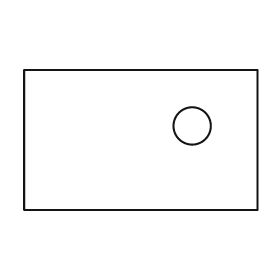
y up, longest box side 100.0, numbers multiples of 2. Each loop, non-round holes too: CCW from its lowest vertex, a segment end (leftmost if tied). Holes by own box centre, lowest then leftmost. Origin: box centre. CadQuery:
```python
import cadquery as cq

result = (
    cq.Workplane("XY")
    .moveTo(-50.0, -30.0)
    .lineTo(50.0, -30.0)
    .lineTo(50.0, 30.0)
    .lineTo(-50.0, 30.0)
    .close()
    .moveTo(22.0, 6.0)
    .circle(8.0)
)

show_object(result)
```